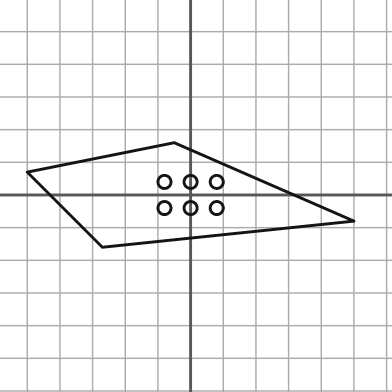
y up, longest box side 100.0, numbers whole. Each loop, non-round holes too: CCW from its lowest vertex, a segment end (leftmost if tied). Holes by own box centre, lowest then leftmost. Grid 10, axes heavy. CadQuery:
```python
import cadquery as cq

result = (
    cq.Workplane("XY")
    .moveTo(-27.0, -16.0)
    .lineTo(50.0, -8.0)
    .lineTo(-5.0, 16.0)
    .lineTo(-50.0, 7.0)
    .close()
    .moveTo(-8.0, -4.0)
    .circle(2.0)
    .moveTo(0.0, -4.0)
    .circle(2.0)
    .moveTo(8.0, -4.0)
    .circle(2.0)
    .moveTo(-8.0, 4.0)
    .circle(2.0)
    .moveTo(0.0, 4.0)
    .circle(2.0)
    .moveTo(8.0, 4.0)
    .circle(2.0)
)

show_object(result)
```